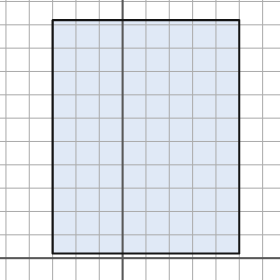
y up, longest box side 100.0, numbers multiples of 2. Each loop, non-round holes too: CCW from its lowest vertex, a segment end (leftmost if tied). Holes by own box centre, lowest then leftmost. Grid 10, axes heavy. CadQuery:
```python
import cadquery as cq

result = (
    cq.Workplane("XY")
    .moveTo(-30.0, 2.0)
    .lineTo(50.0, 2.0)
    .lineTo(50.0, 102.0)
    .lineTo(-30.0, 102.0)
    .close()
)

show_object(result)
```